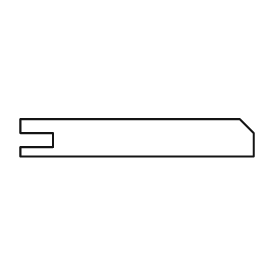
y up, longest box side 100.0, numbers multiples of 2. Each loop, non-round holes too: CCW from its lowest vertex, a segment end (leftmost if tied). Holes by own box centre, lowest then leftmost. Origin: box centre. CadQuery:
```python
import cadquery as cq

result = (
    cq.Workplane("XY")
    .moveTo(-50.0, -8.0)
    .lineTo(50.0, -8.0)
    .lineTo(50.0, 2.0)
    .lineTo(44.0, 8.0)
    .lineTo(-50.0, 8.0)
    .lineTo(-50.0, 2.0)
    .lineTo(-36.0, 2.0)
    .lineTo(-36.0, -4.0)
    .lineTo(-50.0, -4.0)
    .close()
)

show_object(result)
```